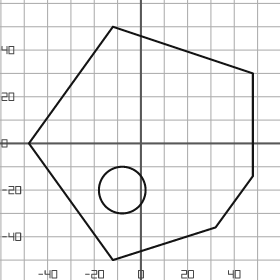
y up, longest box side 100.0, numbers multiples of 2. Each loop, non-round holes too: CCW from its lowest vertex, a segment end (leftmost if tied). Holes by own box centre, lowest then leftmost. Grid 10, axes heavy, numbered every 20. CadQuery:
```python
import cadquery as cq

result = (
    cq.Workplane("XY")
    .moveTo(-12.0, -50.0)
    .lineTo(32.0, -36.0)
    .lineTo(48.0, -14.0)
    .lineTo(48.0, 30.0)
    .lineTo(-12.0, 50.0)
    .lineTo(-48.0, 0.0)
    .close()
    .moveTo(-8.0, -20.0)
    .circle(10.0)
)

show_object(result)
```